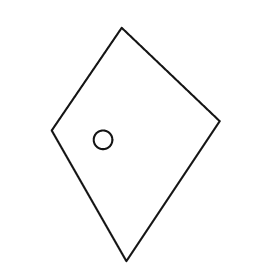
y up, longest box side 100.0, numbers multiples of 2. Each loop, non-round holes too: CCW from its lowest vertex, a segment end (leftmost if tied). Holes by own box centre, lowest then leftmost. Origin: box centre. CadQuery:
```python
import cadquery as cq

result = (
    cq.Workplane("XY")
    .moveTo(-4.0, -50.0)
    .lineTo(36.0, 10.0)
    .lineTo(-6.0, 50.0)
    .lineTo(-36.0, 6.0)
    .close()
    .moveTo(-14.0, 2.0)
    .circle(4.0)
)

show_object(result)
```